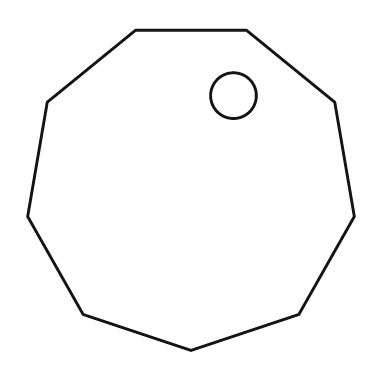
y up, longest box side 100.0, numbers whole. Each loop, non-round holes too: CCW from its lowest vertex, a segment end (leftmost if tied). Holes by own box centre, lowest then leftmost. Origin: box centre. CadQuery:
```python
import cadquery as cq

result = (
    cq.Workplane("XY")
    .moveTo(0.0, -49.0)
    .lineTo(33.0, -38.0)
    .lineTo(50.0, -8.0)
    .lineTo(44.0, 27.0)
    .lineTo(17.0, 49.0)
    .lineTo(-17.0, 49.0)
    .lineTo(-44.0, 27.0)
    .lineTo(-50.0, -8.0)
    .lineTo(-33.0, -38.0)
    .close()
    .moveTo(13.0, 29.0)
    .circle(7.0)
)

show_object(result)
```